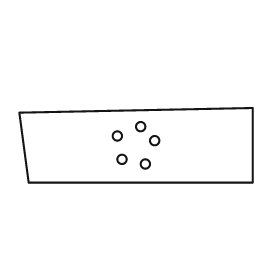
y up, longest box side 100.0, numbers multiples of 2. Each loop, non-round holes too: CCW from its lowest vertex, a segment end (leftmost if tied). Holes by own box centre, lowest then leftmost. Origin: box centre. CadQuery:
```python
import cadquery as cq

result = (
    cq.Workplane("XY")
    .moveTo(-46.0, -16.0)
    .lineTo(50.0, -16.0)
    .lineTo(50.0, 16.0)
    .lineTo(-50.0, 14.0)
    .close()
    .moveTo(4.0, -8.0)
    .circle(2.0)
    .moveTo(-6.0, -6.0)
    .circle(2.0)
    .moveTo(8.0, 2.0)
    .circle(2.0)
    .moveTo(-8.0, 4.0)
    .circle(2.0)
    .moveTo(2.0, 8.0)
    .circle(2.0)
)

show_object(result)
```